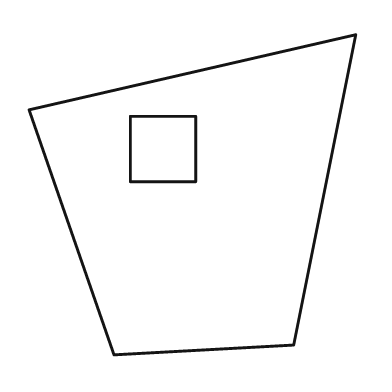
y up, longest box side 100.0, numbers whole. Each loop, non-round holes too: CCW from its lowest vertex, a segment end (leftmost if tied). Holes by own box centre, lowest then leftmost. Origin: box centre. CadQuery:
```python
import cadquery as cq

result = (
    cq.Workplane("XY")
    .moveTo(-24.0, -49.0)
    .lineTo(31.0, -46.0)
    .lineTo(50.0, 49.0)
    .lineTo(-50.0, 26.0)
    .close()
    .moveTo(-19.0, 4.0)
    .lineTo(1.0, 4.0)
    .lineTo(1.0, 24.0)
    .lineTo(-19.0, 24.0)
    .close()
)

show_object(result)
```